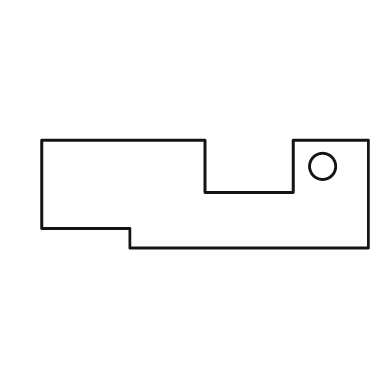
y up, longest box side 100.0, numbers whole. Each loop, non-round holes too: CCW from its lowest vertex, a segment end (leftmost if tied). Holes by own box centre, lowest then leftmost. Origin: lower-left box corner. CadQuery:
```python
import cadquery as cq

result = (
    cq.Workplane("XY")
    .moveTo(27.0, 0.0)
    .lineTo(100.0, 0.0)
    .lineTo(100.0, 33.0)
    .lineTo(77.0, 33.0)
    .lineTo(77.0, 17.0)
    .lineTo(50.0, 17.0)
    .lineTo(50.0, 33.0)
    .lineTo(0.0, 33.0)
    .lineTo(0.0, 6.0)
    .lineTo(27.0, 6.0)
    .close()
    .moveTo(86.0, 25.0)
    .circle(4.0)
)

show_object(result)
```